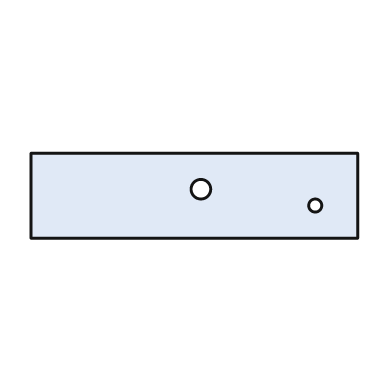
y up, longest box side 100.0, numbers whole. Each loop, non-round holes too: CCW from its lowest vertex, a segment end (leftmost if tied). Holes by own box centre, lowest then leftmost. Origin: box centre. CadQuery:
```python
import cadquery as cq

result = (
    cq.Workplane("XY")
    .moveTo(-50.0, -13.0)
    .lineTo(50.0, -13.0)
    .lineTo(50.0, 13.0)
    .lineTo(-50.0, 13.0)
    .close()
    .moveTo(37.0, -3.0)
    .circle(2.0)
    .moveTo(2.0, 2.0)
    .circle(3.0)
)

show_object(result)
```